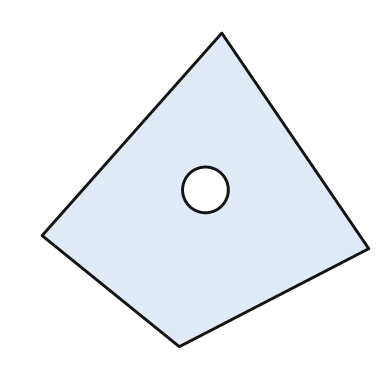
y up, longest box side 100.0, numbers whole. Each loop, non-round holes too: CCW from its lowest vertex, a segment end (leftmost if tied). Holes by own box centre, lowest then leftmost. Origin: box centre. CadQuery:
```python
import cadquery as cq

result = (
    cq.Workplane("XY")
    .moveTo(-8.0, -48.0)
    .lineTo(50.0, -18.0)
    .lineTo(5.0, 48.0)
    .lineTo(-50.0, -14.0)
    .close()
    .moveTo(0.0, 0.0)
    .circle(7.0)
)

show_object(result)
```